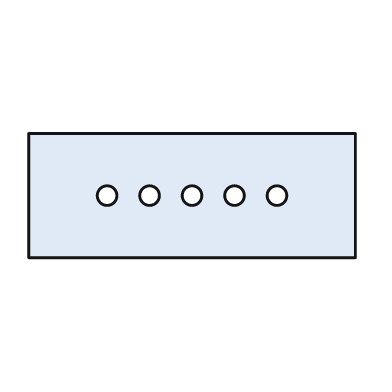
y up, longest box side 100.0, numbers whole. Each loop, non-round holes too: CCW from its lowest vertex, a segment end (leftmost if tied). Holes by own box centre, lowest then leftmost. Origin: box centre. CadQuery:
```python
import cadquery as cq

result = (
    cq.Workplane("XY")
    .moveTo(-50.0, -19.0)
    .lineTo(50.0, -19.0)
    .lineTo(50.0, 19.0)
    .lineTo(-50.0, 19.0)
    .close()
    .moveTo(-26.0, 0.0)
    .circle(3.0)
    .moveTo(-13.0, 0.0)
    .circle(3.0)
    .moveTo(0.0, 0.0)
    .circle(3.0)
    .moveTo(13.0, 0.0)
    .circle(3.0)
    .moveTo(26.0, 0.0)
    .circle(3.0)
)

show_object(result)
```